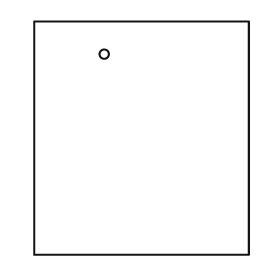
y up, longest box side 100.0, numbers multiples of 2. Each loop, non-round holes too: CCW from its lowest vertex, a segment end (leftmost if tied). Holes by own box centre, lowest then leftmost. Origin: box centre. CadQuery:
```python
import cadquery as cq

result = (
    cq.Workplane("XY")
    .moveTo(-46.0, -50.0)
    .lineTo(46.0, -50.0)
    .lineTo(46.0, 50.0)
    .lineTo(-46.0, 50.0)
    .close()
    .moveTo(-16.0, 36.0)
    .circle(2.0)
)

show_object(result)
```